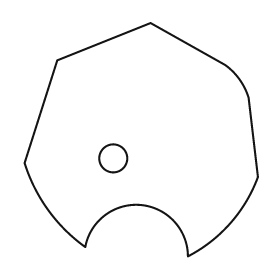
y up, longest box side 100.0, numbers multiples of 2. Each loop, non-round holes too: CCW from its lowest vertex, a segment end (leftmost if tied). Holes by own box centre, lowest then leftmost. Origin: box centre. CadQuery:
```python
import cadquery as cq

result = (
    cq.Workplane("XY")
    .moveTo(20.0, -50.0)
    .threePointArc((38.0, -36.0), (50.0, -16.0))
    .lineTo(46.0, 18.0)
    .threePointArc((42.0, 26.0), (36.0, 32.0))
    .lineTo(4.0, 50.0)
    .lineTo(-36.0, 34.0)
    .lineTo(-50.0, -10.0)
    .threePointArc((-40.0, -30.0), (-24.0, -46.0))
    .threePointArc((0.0, -28.0), (20.0, -50.0))
    .close()
    .moveTo(-12.0, -8.0)
    .circle(6.0)
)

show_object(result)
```